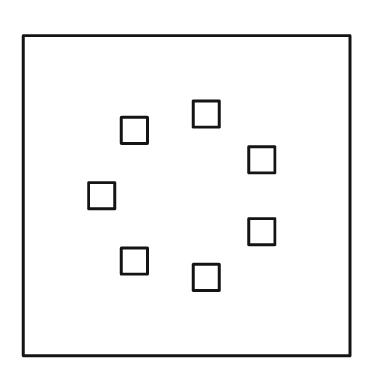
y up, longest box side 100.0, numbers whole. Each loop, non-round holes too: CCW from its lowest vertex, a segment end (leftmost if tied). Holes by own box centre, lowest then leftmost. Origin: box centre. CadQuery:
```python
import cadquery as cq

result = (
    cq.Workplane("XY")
    .moveTo(-50.0, -49.0)
    .lineTo(50.0, -49.0)
    .lineTo(50.0, 49.0)
    .lineTo(-50.0, 49.0)
    .close()
    .moveTo(2.0, -29.0)
    .lineTo(10.0, -29.0)
    .lineTo(10.0, -21.0)
    .lineTo(2.0, -21.0)
    .close()
    .moveTo(-20.0, -24.0)
    .lineTo(-12.0, -24.0)
    .lineTo(-12.0, -16.0)
    .lineTo(-20.0, -16.0)
    .close()
    .moveTo(19.0, -15.0)
    .lineTo(27.0, -15.0)
    .lineTo(27.0, -7.0)
    .lineTo(19.0, -7.0)
    .close()
    .moveTo(-30.0, -4.0)
    .lineTo(-22.0, -4.0)
    .lineTo(-22.0, 4.0)
    .lineTo(-30.0, 4.0)
    .close()
    .moveTo(19.0, 7.0)
    .lineTo(27.0, 7.0)
    .lineTo(27.0, 15.0)
    .lineTo(19.0, 15.0)
    .close()
    .moveTo(-20.0, 16.0)
    .lineTo(-12.0, 16.0)
    .lineTo(-12.0, 24.0)
    .lineTo(-20.0, 24.0)
    .close()
    .moveTo(2.0, 21.0)
    .lineTo(10.0, 21.0)
    .lineTo(10.0, 29.0)
    .lineTo(2.0, 29.0)
    .close()
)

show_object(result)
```